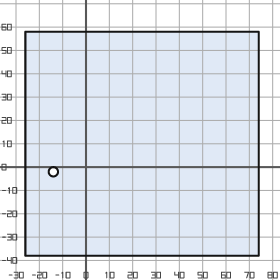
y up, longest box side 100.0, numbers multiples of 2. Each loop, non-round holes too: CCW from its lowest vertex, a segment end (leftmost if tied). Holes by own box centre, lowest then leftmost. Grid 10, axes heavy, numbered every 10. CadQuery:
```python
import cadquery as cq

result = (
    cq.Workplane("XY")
    .moveTo(-26.0, -38.0)
    .lineTo(74.0, -38.0)
    .lineTo(74.0, 58.0)
    .lineTo(-26.0, 58.0)
    .close()
    .moveTo(-14.0, -2.0)
    .circle(2.0)
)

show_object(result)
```